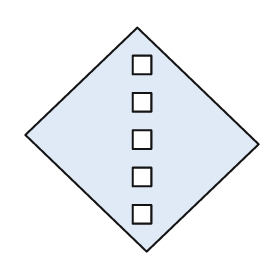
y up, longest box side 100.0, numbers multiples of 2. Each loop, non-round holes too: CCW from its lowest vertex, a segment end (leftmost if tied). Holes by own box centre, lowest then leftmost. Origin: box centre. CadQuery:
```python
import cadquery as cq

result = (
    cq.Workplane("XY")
    .moveTo(2.0, -48.0)
    .lineTo(50.0, -2.0)
    .lineTo(-2.0, 48.0)
    .lineTo(-50.0, 2.0)
    .close()
    .moveTo(-4.0, -36.0)
    .lineTo(4.0, -36.0)
    .lineTo(4.0, -28.0)
    .lineTo(-4.0, -28.0)
    .close()
    .moveTo(-4.0, -20.0)
    .lineTo(4.0, -20.0)
    .lineTo(4.0, -12.0)
    .lineTo(-4.0, -12.0)
    .close()
    .moveTo(-4.0, -4.0)
    .lineTo(4.0, -4.0)
    .lineTo(4.0, 4.0)
    .lineTo(-4.0, 4.0)
    .close()
    .moveTo(-4.0, 12.0)
    .lineTo(4.0, 12.0)
    .lineTo(4.0, 20.0)
    .lineTo(-4.0, 20.0)
    .close()
    .moveTo(-4.0, 28.0)
    .lineTo(4.0, 28.0)
    .lineTo(4.0, 36.0)
    .lineTo(-4.0, 36.0)
    .close()
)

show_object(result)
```